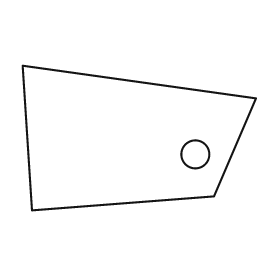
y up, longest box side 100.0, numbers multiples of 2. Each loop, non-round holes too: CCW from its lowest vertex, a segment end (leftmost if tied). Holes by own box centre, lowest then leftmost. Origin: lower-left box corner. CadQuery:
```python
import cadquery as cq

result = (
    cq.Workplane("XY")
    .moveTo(4.0, 0.0)
    .lineTo(82.0, 6.0)
    .lineTo(100.0, 48.0)
    .lineTo(0.0, 62.0)
    .close()
    .moveTo(74.0, 24.0)
    .circle(6.0)
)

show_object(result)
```